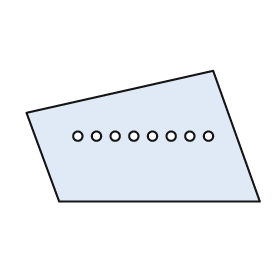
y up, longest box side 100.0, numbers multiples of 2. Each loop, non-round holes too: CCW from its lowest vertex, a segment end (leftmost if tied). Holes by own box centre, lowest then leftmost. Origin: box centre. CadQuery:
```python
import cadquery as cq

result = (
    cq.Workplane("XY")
    .moveTo(-36.0, -28.0)
    .lineTo(50.0, -28.0)
    .lineTo(30.0, 28.0)
    .lineTo(-50.0, 10.0)
    .close()
    .moveTo(-28.0, 0.0)
    .circle(2.0)
    .moveTo(-20.0, 0.0)
    .circle(2.0)
    .moveTo(-12.0, 0.0)
    .circle(2.0)
    .moveTo(-4.0, 0.0)
    .circle(2.0)
    .moveTo(4.0, 0.0)
    .circle(2.0)
    .moveTo(12.0, 0.0)
    .circle(2.0)
    .moveTo(20.0, 0.0)
    .circle(2.0)
    .moveTo(28.0, 0.0)
    .circle(2.0)
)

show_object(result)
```